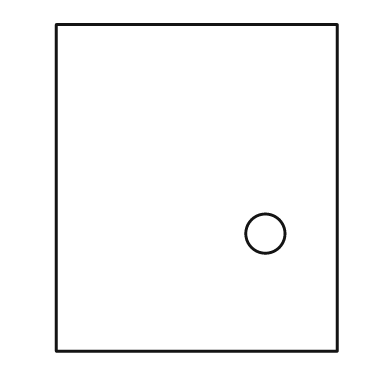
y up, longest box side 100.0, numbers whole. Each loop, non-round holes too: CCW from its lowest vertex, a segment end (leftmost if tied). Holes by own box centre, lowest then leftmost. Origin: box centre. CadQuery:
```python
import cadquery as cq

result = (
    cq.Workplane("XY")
    .moveTo(-43.0, -50.0)
    .lineTo(43.0, -50.0)
    .lineTo(43.0, 50.0)
    .lineTo(-43.0, 50.0)
    .close()
    .moveTo(21.0, -14.0)
    .circle(6.0)
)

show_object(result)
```